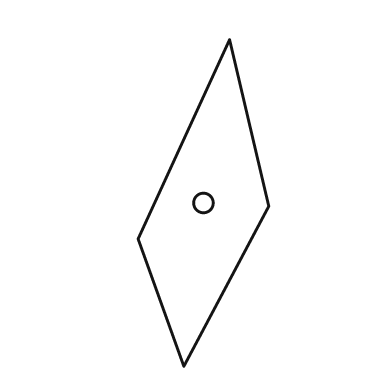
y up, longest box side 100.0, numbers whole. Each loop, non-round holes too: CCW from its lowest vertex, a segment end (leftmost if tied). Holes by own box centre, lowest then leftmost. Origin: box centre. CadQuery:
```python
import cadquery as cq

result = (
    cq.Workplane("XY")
    .moveTo(-6.0, -50.0)
    .lineTo(20.0, -1.0)
    .lineTo(8.0, 50.0)
    .lineTo(-20.0, -11.0)
    .close()
    .moveTo(0.0, 0.0)
    .circle(3.0)
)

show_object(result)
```